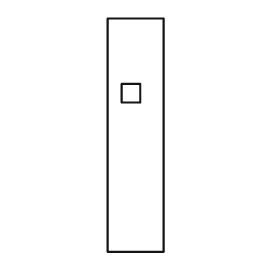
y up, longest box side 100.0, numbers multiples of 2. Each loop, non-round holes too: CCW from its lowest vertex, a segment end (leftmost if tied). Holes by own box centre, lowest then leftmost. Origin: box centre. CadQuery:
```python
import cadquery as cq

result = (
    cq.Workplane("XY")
    .moveTo(-12.0, -50.0)
    .lineTo(12.0, -50.0)
    .lineTo(12.0, 50.0)
    .lineTo(-12.0, 50.0)
    .close()
    .moveTo(-6.0, 14.0)
    .lineTo(2.0, 14.0)
    .lineTo(2.0, 22.0)
    .lineTo(-6.0, 22.0)
    .close()
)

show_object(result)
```